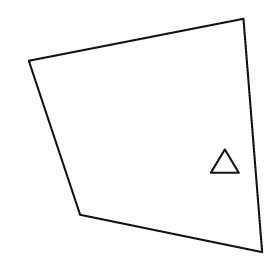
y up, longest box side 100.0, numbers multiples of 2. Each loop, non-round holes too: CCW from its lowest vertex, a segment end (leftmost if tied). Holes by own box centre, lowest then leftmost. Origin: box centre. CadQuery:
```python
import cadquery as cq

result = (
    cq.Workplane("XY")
    .moveTo(50.0, -50.0)
    .lineTo(42.0, 50.0)
    .lineTo(-50.0, 32.0)
    .lineTo(-28.0, -34.0)
    .close()
    .moveTo(28.0, -16.0)
    .lineTo(40.0, -16.0)
    .lineTo(34.0, -6.0)
    .close()
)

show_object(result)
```